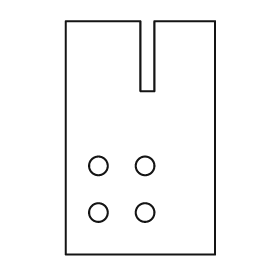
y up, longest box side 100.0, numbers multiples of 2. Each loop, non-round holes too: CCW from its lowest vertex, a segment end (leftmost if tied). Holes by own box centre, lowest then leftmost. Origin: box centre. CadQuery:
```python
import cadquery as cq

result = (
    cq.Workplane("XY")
    .moveTo(-32.0, -50.0)
    .lineTo(32.0, -50.0)
    .lineTo(32.0, 50.0)
    .lineTo(6.0, 50.0)
    .lineTo(6.0, 20.0)
    .lineTo(0.0, 20.0)
    .lineTo(0.0, 50.0)
    .lineTo(-32.0, 50.0)
    .close()
    .moveTo(-18.0, -32.0)
    .circle(4.0)
    .moveTo(2.0, -32.0)
    .circle(4.0)
    .moveTo(-18.0, -12.0)
    .circle(4.0)
    .moveTo(2.0, -12.0)
    .circle(4.0)
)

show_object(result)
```